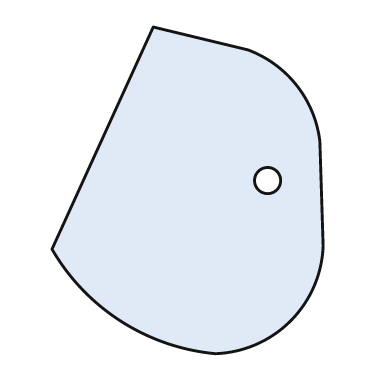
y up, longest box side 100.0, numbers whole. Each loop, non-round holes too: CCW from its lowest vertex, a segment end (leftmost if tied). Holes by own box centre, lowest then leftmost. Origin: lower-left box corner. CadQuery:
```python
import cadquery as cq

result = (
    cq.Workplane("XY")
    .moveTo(50.0, 0.0)
    .threePointArc((73.0, 10.0), (83.0, 33.0))
    .lineTo(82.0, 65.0)
    .threePointArc((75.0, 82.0), (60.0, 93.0))
    .lineTo(31.0, 100.0)
    .lineTo(0.0, 32.0)
    .threePointArc((21.0, 10.0), (50.0, 0.0))
    .close()
    .moveTo(66.0, 53.0)
    .circle(4.0)
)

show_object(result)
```